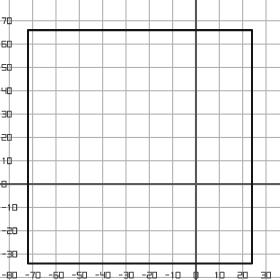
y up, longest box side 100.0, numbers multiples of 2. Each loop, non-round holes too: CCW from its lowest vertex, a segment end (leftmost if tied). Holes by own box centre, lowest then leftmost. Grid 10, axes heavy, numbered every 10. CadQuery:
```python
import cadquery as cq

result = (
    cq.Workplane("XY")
    .moveTo(-72.0, -34.0)
    .lineTo(24.0, -34.0)
    .lineTo(24.0, 66.0)
    .lineTo(-72.0, 66.0)
    .close()
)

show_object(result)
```